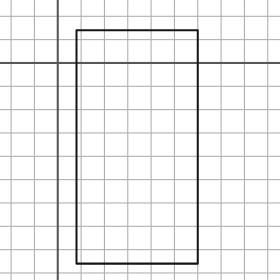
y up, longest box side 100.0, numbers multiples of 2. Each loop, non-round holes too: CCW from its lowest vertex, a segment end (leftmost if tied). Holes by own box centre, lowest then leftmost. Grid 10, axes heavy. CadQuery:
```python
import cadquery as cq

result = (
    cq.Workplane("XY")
    .moveTo(8.0, -86.0)
    .lineTo(60.0, -86.0)
    .lineTo(60.0, 14.0)
    .lineTo(8.0, 14.0)
    .close()
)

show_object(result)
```